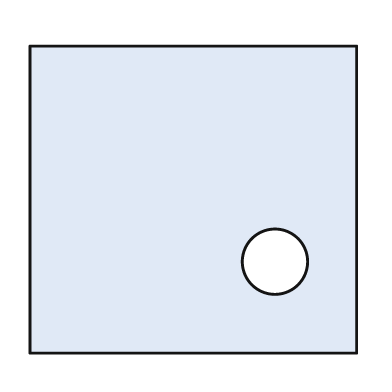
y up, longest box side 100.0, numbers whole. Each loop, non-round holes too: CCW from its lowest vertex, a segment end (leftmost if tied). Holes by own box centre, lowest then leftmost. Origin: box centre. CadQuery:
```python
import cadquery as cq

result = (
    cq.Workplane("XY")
    .moveTo(-50.0, -47.0)
    .lineTo(50.0, -47.0)
    .lineTo(50.0, 47.0)
    .lineTo(-50.0, 47.0)
    .close()
    .moveTo(25.0, -19.0)
    .circle(10.0)
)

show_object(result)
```